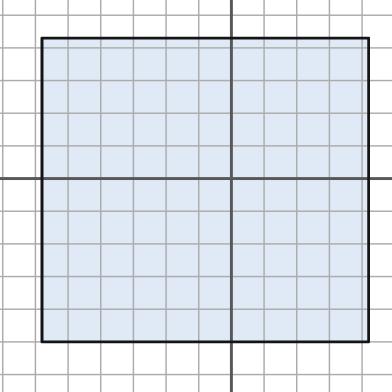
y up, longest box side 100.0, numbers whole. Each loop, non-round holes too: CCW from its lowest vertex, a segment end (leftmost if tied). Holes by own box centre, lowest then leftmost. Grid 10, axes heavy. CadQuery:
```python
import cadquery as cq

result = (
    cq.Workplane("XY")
    .moveTo(-58.0, -50.0)
    .lineTo(42.0, -50.0)
    .lineTo(42.0, 43.0)
    .lineTo(-58.0, 43.0)
    .close()
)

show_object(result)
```